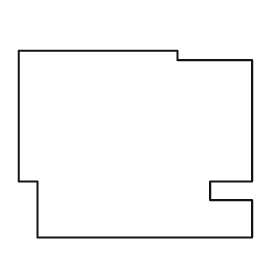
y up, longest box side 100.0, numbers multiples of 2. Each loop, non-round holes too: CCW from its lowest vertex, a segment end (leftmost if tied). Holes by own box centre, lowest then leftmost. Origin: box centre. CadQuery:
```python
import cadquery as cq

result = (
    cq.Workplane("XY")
    .moveTo(-42.0, -40.0)
    .lineTo(50.0, -40.0)
    .lineTo(50.0, -24.0)
    .lineTo(32.0, -24.0)
    .lineTo(32.0, -16.0)
    .lineTo(50.0, -16.0)
    .lineTo(50.0, 36.0)
    .lineTo(18.0, 36.0)
    .lineTo(18.0, 40.0)
    .lineTo(-50.0, 40.0)
    .lineTo(-50.0, -16.0)
    .lineTo(-42.0, -16.0)
    .close()
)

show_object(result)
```